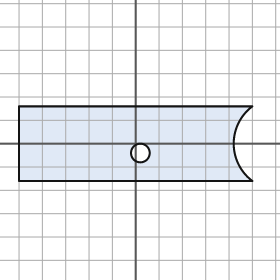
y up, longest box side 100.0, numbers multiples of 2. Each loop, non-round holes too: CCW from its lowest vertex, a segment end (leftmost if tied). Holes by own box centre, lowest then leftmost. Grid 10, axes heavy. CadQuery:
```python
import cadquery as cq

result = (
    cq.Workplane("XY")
    .moveTo(-50.0, -16.0)
    .lineTo(50.0, -16.0)
    .threePointArc((42.0, 0.0), (50.0, 16.0))
    .lineTo(-50.0, 16.0)
    .close()
    .moveTo(2.0, -4.0)
    .circle(4.0)
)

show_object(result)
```